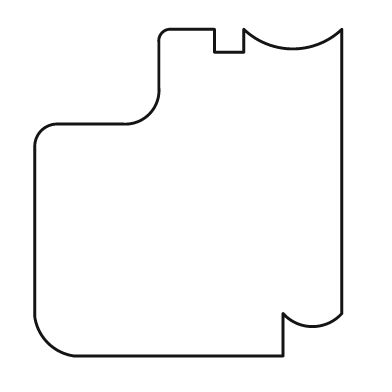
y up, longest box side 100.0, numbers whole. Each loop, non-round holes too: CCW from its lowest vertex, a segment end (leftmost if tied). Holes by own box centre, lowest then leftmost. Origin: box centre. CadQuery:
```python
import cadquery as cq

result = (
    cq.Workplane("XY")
    .moveTo(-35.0, -50.0)
    .lineTo(29.0, -50.0)
    .lineTo(29.0, -37.0)
    .threePointArc((38.0, -41.0), (47.0, -37.0))
    .lineTo(47.0, 50.0)
    .threePointArc((32.0, 44.0), (17.0, 50.0))
    .lineTo(17.0, 43.0)
    .lineTo(8.0, 43.0)
    .lineTo(8.0, 50.0)
    .lineTo(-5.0, 50.0)
    .threePointArc((-8.0, 49.0), (-9.0, 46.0))
    .lineTo(-9.0, 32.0)
    .threePointArc((-12.0, 24.0), (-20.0, 21.0))
    .lineTo(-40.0, 21.0)
    .threePointArc((-45.0, 19.0), (-47.0, 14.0))
    .lineTo(-47.0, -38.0)
    .threePointArc((-43.0, -46.0), (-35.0, -50.0))
    .close()
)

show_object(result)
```